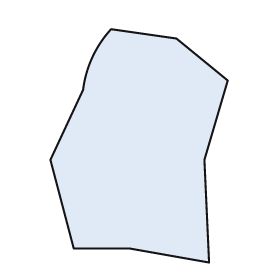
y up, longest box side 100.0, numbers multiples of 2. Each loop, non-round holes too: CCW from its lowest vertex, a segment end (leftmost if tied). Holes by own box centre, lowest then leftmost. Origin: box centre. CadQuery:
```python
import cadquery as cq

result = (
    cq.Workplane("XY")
    .moveTo(30.0, -50.0)
    .lineTo(28.0, -6.0)
    .lineTo(38.0, 28.0)
    .lineTo(16.0, 46.0)
    .lineTo(-12.0, 50.0)
    .threePointArc((-20.0, 38.0), (-24.0, 24.0))
    .lineTo(-38.0, -6.0)
    .lineTo(-28.0, -44.0)
    .lineTo(-4.0, -44.0)
    .close()
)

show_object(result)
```